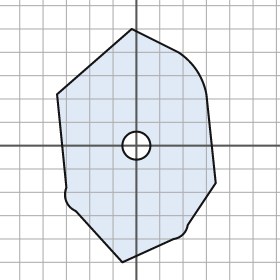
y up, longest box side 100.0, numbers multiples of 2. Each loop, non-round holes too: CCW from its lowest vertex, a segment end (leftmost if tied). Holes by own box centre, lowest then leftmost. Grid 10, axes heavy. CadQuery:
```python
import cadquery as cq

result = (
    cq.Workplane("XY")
    .moveTo(-6.0, -50.0)
    .lineTo(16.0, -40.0)
    .threePointArc((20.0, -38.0), (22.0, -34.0))
    .lineTo(34.0, -16.0)
    .lineTo(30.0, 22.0)
    .threePointArc((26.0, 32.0), (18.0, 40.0))
    .lineTo(-2.0, 50.0)
    .lineTo(-34.0, 22.0)
    .lineTo(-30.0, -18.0)
    .threePointArc((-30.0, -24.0), (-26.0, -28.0))
    .close()
    .moveTo(0.0, 0.0)
    .circle(6.0)
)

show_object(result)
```